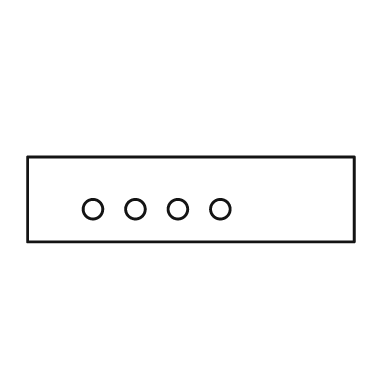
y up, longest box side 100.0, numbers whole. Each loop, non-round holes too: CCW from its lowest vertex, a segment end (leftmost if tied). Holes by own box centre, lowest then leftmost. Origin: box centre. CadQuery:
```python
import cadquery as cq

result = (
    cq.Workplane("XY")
    .moveTo(-50.0, -13.0)
    .lineTo(50.0, -13.0)
    .lineTo(50.0, 13.0)
    .lineTo(-50.0, 13.0)
    .close()
    .moveTo(-30.0, -3.0)
    .circle(3.0)
    .moveTo(-17.0, -3.0)
    .circle(3.0)
    .moveTo(-4.0, -3.0)
    .circle(3.0)
    .moveTo(9.0, -3.0)
    .circle(3.0)
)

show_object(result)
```